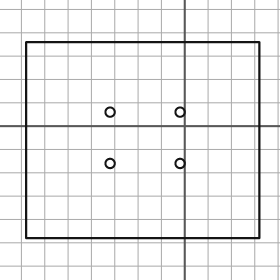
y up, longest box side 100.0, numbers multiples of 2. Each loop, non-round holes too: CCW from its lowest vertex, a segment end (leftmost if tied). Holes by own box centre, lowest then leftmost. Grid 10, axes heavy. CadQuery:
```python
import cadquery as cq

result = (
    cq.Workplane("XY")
    .moveTo(-68.0, -48.0)
    .lineTo(32.0, -48.0)
    .lineTo(32.0, 36.0)
    .lineTo(-68.0, 36.0)
    .close()
    .moveTo(-32.0, -16.0)
    .circle(2.0)
    .moveTo(-2.0, -16.0)
    .circle(2.0)
    .moveTo(-32.0, 6.0)
    .circle(2.0)
    .moveTo(-2.0, 6.0)
    .circle(2.0)
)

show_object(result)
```